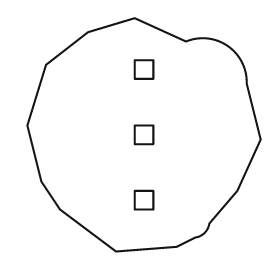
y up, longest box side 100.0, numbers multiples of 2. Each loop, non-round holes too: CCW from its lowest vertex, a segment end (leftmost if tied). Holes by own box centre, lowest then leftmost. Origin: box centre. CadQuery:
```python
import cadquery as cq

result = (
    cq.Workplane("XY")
    .moveTo(-12.0, -50.0)
    .lineTo(14.0, -48.0)
    .lineTo(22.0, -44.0)
    .threePointArc((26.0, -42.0), (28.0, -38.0))
    .lineTo(40.0, -24.0)
    .lineTo(50.0, -2.0)
    .lineTo(44.0, 22.0)
    .threePointArc((36.0, 38.0), (18.0, 40.0))
    .lineTo(-4.0, 50.0)
    .lineTo(-24.0, 44.0)
    .lineTo(-42.0, 30.0)
    .lineTo(-50.0, 4.0)
    .lineTo(-44.0, -20.0)
    .lineTo(-36.0, -32.0)
    .close()
    .moveTo(-4.0, -32.0)
    .lineTo(4.0, -32.0)
    .lineTo(4.0, -24.0)
    .lineTo(-4.0, -24.0)
    .close()
    .moveTo(-4.0, -4.0)
    .lineTo(4.0, -4.0)
    .lineTo(4.0, 4.0)
    .lineTo(-4.0, 4.0)
    .close()
    .moveTo(-4.0, 24.0)
    .lineTo(4.0, 24.0)
    .lineTo(4.0, 32.0)
    .lineTo(-4.0, 32.0)
    .close()
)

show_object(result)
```